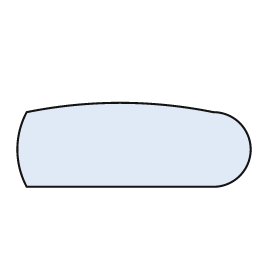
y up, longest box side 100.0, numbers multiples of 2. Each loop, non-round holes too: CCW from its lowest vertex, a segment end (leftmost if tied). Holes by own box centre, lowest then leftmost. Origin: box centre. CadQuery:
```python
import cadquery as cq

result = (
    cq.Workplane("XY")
    .moveTo(-46.0, -18.0)
    .lineTo(34.0, -18.0)
    .threePointArc((50.0, -2.0), (34.0, 14.0))
    .threePointArc((-6.0, 18.0), (-46.0, 14.0))
    .threePointArc((-50.0, -2.0), (-46.0, -18.0))
    .close()
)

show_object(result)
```